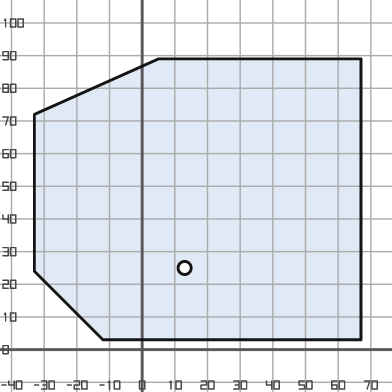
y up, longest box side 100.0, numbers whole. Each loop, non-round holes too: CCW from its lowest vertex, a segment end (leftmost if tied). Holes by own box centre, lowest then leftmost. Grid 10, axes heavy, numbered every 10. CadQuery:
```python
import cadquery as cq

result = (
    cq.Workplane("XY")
    .moveTo(-12.0, 3.0)
    .lineTo(67.0, 3.0)
    .lineTo(67.0, 89.0)
    .lineTo(5.0, 89.0)
    .lineTo(-33.0, 72.0)
    .lineTo(-33.0, 24.0)
    .close()
    .moveTo(13.0, 25.0)
    .circle(2.0)
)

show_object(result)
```